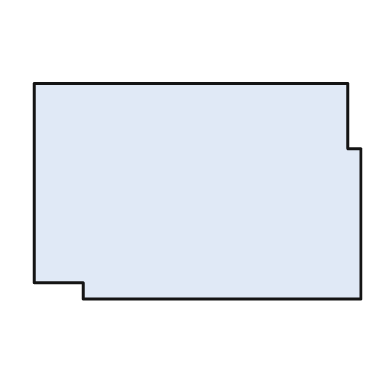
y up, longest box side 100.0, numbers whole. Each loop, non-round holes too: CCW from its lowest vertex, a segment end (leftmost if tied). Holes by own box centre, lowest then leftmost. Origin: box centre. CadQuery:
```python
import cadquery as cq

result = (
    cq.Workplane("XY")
    .moveTo(-35.0, -33.0)
    .lineTo(50.0, -33.0)
    .lineTo(50.0, 13.0)
    .lineTo(46.0, 13.0)
    .lineTo(46.0, 33.0)
    .lineTo(-50.0, 33.0)
    .lineTo(-50.0, -28.0)
    .lineTo(-35.0, -28.0)
    .close()
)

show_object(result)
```